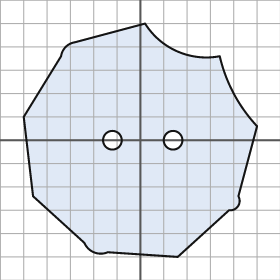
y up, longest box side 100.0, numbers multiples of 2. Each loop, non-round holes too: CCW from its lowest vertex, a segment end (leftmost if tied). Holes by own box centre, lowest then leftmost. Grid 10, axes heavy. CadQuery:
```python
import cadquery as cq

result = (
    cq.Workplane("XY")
    .moveTo(16.0, -50.0)
    .lineTo(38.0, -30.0)
    .threePointArc((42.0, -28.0), (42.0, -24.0))
    .lineTo(50.0, 6.0)
    .threePointArc((40.0, 20.0), (34.0, 36.0))
    .threePointArc((16.0, 38.0), (2.0, 50.0))
    .lineTo(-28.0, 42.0)
    .threePointArc((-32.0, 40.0), (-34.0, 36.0))
    .lineTo(-50.0, 10.0)
    .lineTo(-46.0, -24.0)
    .lineTo(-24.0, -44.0)
    .threePointArc((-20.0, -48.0), (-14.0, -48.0))
    .close()
    .moveTo(-12.0, 0.0)
    .circle(4.0)
    .moveTo(14.0, 0.0)
    .circle(4.0)
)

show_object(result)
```